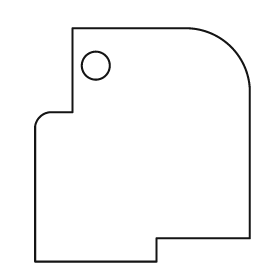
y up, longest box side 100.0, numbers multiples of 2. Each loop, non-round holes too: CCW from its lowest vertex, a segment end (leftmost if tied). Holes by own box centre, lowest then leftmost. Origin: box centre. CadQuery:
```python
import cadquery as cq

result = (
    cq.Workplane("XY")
    .moveTo(-46.0, -50.0)
    .lineTo(6.0, -50.0)
    .lineTo(6.0, -40.0)
    .lineTo(46.0, -40.0)
    .lineTo(46.0, 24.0)
    .threePointArc((38.0, 42.0), (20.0, 50.0))
    .lineTo(-30.0, 50.0)
    .lineTo(-30.0, 14.0)
    .lineTo(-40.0, 14.0)
    .threePointArc((-44.0, 12.0), (-46.0, 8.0))
    .close()
    .moveTo(-20.0, 34.0)
    .circle(6.0)
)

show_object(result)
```